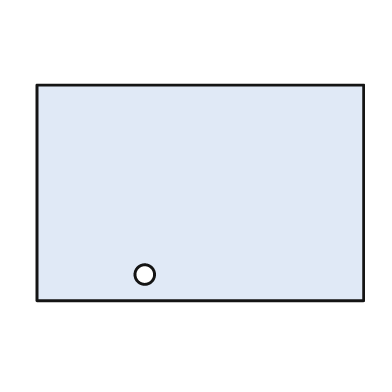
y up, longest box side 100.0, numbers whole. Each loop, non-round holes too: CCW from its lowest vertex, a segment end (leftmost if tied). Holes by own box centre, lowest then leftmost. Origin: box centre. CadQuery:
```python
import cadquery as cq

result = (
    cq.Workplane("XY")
    .moveTo(-50.0, -33.0)
    .lineTo(50.0, -33.0)
    .lineTo(50.0, 33.0)
    .lineTo(-50.0, 33.0)
    .close()
    .moveTo(-17.0, -25.0)
    .circle(3.0)
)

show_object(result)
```